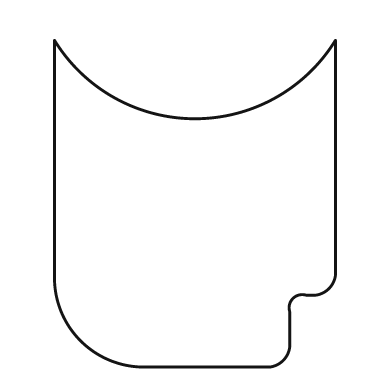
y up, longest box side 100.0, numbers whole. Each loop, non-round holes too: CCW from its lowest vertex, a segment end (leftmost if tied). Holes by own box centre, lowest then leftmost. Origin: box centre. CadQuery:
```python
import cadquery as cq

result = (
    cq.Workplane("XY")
    .moveTo(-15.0, -50.0)
    .lineTo(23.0, -50.0)
    .threePointArc((27.0, -48.0), (29.0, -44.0))
    .lineTo(29.0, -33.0)
    .threePointArc((30.0, -29.0), (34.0, -28.0))
    .lineTo(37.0, -28.0)
    .threePointArc((41.0, -26.0), (43.0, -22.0))
    .lineTo(43.0, 50.0)
    .threePointArc((0.0, 26.0), (-43.0, 50.0))
    .lineTo(-43.0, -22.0)
    .threePointArc((-35.0, -42.0), (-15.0, -50.0))
    .close()
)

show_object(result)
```